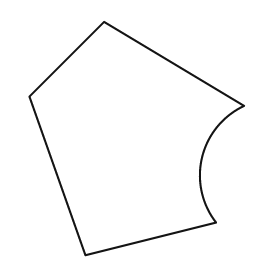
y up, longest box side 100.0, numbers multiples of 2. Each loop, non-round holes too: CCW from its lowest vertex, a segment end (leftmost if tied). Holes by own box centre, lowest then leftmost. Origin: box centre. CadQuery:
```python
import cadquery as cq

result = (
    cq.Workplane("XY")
    .moveTo(-22.0, -50.0)
    .lineTo(34.0, -36.0)
    .threePointArc((28.0, -8.0), (46.0, 14.0))
    .lineTo(-14.0, 50.0)
    .lineTo(-46.0, 18.0)
    .close()
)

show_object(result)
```